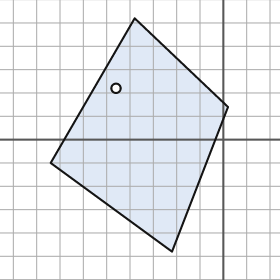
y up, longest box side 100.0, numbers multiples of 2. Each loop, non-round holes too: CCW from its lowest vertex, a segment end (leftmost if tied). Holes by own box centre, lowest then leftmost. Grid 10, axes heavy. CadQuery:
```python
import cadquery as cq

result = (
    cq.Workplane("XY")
    .moveTo(-22.0, -48.0)
    .lineTo(2.0, 14.0)
    .lineTo(-38.0, 52.0)
    .lineTo(-74.0, -10.0)
    .close()
    .moveTo(-46.0, 22.0)
    .circle(2.0)
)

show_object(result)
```